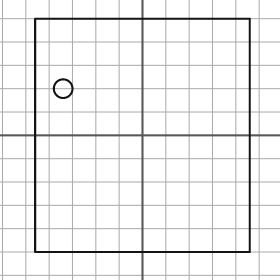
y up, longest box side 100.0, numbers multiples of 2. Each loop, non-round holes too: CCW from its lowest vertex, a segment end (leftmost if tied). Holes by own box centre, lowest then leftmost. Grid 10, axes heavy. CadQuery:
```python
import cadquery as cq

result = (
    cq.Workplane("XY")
    .moveTo(-46.0, -50.0)
    .lineTo(46.0, -50.0)
    .lineTo(46.0, 50.0)
    .lineTo(-46.0, 50.0)
    .close()
    .moveTo(-34.0, 20.0)
    .circle(4.0)
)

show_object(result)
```